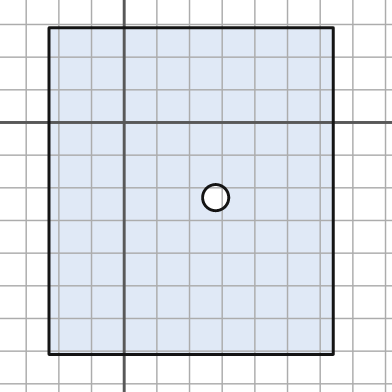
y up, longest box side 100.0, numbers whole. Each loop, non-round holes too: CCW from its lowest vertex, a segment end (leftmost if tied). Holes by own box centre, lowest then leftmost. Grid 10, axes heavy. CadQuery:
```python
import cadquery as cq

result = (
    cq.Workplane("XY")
    .moveTo(-23.0, -71.0)
    .lineTo(64.0, -71.0)
    .lineTo(64.0, 29.0)
    .lineTo(-23.0, 29.0)
    .close()
    .moveTo(28.0, -23.0)
    .circle(4.0)
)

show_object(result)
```